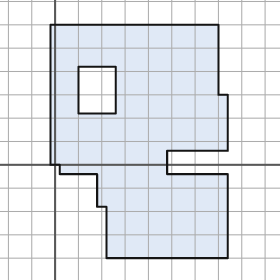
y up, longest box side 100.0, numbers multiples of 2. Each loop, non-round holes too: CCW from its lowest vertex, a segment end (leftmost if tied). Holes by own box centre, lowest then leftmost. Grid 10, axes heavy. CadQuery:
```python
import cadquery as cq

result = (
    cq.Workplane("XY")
    .moveTo(22.0, -40.0)
    .lineTo(74.0, -40.0)
    .lineTo(74.0, -4.0)
    .lineTo(48.0, -4.0)
    .lineTo(48.0, 6.0)
    .lineTo(74.0, 6.0)
    .lineTo(74.0, 30.0)
    .lineTo(70.0, 30.0)
    .lineTo(70.0, 60.0)
    .lineTo(-2.0, 60.0)
    .lineTo(-2.0, 0.0)
    .lineTo(2.0, 0.0)
    .lineTo(2.0, -4.0)
    .lineTo(18.0, -4.0)
    .lineTo(18.0, -18.0)
    .lineTo(22.0, -18.0)
    .close()
    .moveTo(10.0, 22.0)
    .lineTo(26.0, 22.0)
    .lineTo(26.0, 42.0)
    .lineTo(10.0, 42.0)
    .close()
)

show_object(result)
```